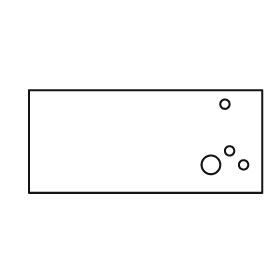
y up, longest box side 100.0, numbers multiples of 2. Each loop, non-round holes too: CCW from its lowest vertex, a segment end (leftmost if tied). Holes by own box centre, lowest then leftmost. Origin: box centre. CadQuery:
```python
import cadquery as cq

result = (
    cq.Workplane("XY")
    .moveTo(-50.0, -22.0)
    .lineTo(50.0, -22.0)
    .lineTo(50.0, 22.0)
    .lineTo(-50.0, 22.0)
    .close()
    .moveTo(28.0, -10.0)
    .circle(4.0)
    .moveTo(42.0, -10.0)
    .circle(2.0)
    .moveTo(36.0, -4.0)
    .circle(2.0)
    .moveTo(34.0, 16.0)
    .circle(2.0)
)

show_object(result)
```